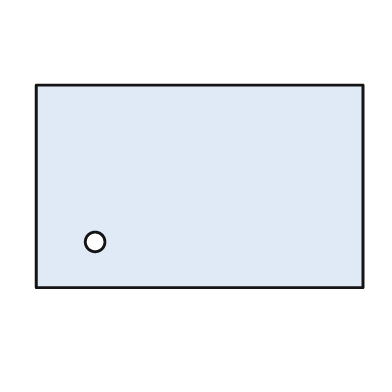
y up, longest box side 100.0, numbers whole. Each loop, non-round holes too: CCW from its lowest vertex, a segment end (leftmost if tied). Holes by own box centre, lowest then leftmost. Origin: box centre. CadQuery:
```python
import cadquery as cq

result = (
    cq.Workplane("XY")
    .moveTo(-50.0, -31.0)
    .lineTo(50.0, -31.0)
    .lineTo(50.0, 31.0)
    .lineTo(-50.0, 31.0)
    .close()
    .moveTo(-32.0, -17.0)
    .circle(3.0)
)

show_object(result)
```